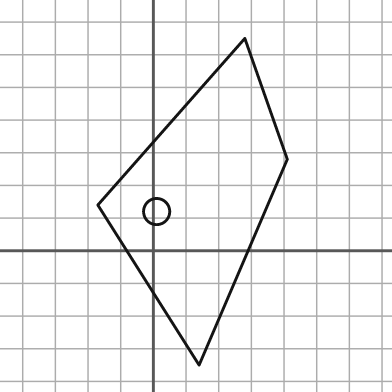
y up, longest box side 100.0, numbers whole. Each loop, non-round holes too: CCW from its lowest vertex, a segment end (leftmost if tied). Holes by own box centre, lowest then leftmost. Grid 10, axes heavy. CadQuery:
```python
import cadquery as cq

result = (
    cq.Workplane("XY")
    .moveTo(14.0, -35.0)
    .lineTo(41.0, 28.0)
    .lineTo(28.0, 65.0)
    .lineTo(-17.0, 14.0)
    .close()
    .moveTo(1.0, 12.0)
    .circle(4.0)
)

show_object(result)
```